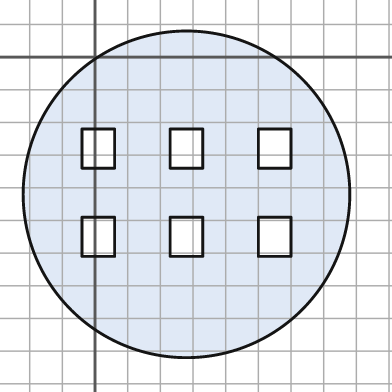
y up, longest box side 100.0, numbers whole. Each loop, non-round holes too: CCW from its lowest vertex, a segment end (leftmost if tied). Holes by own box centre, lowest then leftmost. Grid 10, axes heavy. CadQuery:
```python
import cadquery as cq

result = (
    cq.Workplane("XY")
    .moveTo(28.0, -42.0)
    .circle(50.0)
    .moveTo(-4.0, -61.0)
    .lineTo(6.0, -61.0)
    .lineTo(6.0, -49.0)
    .lineTo(-4.0, -49.0)
    .close()
    .moveTo(23.0, -61.0)
    .lineTo(33.0, -61.0)
    .lineTo(33.0, -49.0)
    .lineTo(23.0, -49.0)
    .close()
    .moveTo(50.0, -61.0)
    .lineTo(60.0, -61.0)
    .lineTo(60.0, -49.0)
    .lineTo(50.0, -49.0)
    .close()
    .moveTo(-4.0, -34.0)
    .lineTo(6.0, -34.0)
    .lineTo(6.0, -22.0)
    .lineTo(-4.0, -22.0)
    .close()
    .moveTo(23.0, -34.0)
    .lineTo(33.0, -34.0)
    .lineTo(33.0, -22.0)
    .lineTo(23.0, -22.0)
    .close()
    .moveTo(50.0, -34.0)
    .lineTo(60.0, -34.0)
    .lineTo(60.0, -22.0)
    .lineTo(50.0, -22.0)
    .close()
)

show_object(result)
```